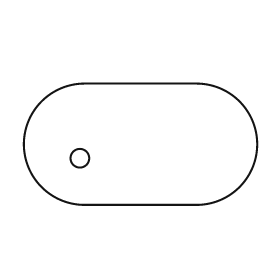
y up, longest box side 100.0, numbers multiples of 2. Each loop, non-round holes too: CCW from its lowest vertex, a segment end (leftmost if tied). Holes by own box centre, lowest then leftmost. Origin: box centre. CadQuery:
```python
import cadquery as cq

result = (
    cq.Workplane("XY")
    .moveTo(-24.0, -26.0)
    .lineTo(24.0, -26.0)
    .threePointArc((50.0, 0.0), (24.0, 26.0))
    .lineTo(-24.0, 26.0)
    .threePointArc((-50.0, 0.0), (-24.0, -26.0))
    .close()
    .moveTo(-26.0, -6.0)
    .circle(4.0)
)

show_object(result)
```